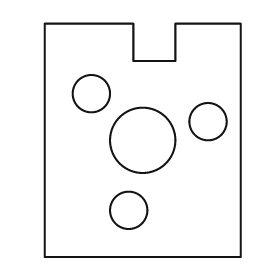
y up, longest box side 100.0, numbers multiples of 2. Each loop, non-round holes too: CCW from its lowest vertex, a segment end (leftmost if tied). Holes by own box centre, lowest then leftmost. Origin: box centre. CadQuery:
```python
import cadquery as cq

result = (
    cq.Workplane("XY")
    .moveTo(-42.0, -50.0)
    .lineTo(42.0, -50.0)
    .lineTo(42.0, 50.0)
    .lineTo(14.0, 50.0)
    .lineTo(14.0, 34.0)
    .lineTo(-4.0, 34.0)
    .lineTo(-4.0, 50.0)
    .lineTo(-42.0, 50.0)
    .close()
    .moveTo(-6.0, -30.0)
    .circle(8.0)
    .moveTo(0.0, 0.0)
    .circle(14.0)
    .moveTo(28.0, 8.0)
    .circle(8.0)
    .moveTo(-22.0, 20.0)
    .circle(8.0)
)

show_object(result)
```